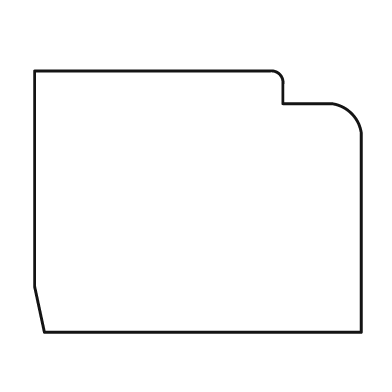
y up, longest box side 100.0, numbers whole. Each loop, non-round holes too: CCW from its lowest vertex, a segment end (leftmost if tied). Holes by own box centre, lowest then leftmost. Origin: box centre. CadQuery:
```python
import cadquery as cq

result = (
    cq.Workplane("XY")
    .moveTo(-47.0, -40.0)
    .lineTo(50.0, -40.0)
    .lineTo(50.0, 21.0)
    .threePointArc((47.0, 27.0), (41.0, 30.0))
    .lineTo(26.0, 30.0)
    .lineTo(26.0, 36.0)
    .threePointArc((25.0, 39.0), (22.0, 40.0))
    .lineTo(-50.0, 40.0)
    .lineTo(-50.0, -26.0)
    .close()
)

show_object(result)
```